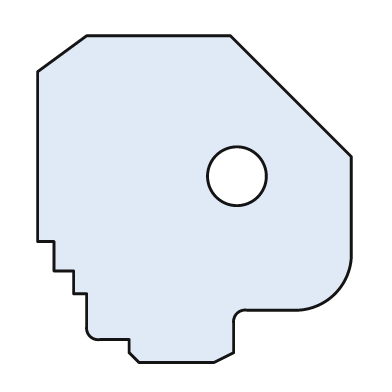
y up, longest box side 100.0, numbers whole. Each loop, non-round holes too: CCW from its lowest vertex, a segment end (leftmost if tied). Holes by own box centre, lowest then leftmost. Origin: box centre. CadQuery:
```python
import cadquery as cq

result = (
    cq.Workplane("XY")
    .moveTo(-17.0, -50.0)
    .lineTo(6.0, -50.0)
    .lineTo(12.0, -47.0)
    .lineTo(12.0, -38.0)
    .threePointArc((13.0, -35.0), (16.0, -34.0))
    .lineTo(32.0, -34.0)
    .threePointArc((43.0, -29.0), (48.0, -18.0))
    .lineTo(48.0, 13.0)
    .lineTo(11.0, 50.0)
    .lineTo(-33.0, 50.0)
    .lineTo(-48.0, 39.0)
    .lineTo(-48.0, -13.0)
    .lineTo(-43.0, -13.0)
    .lineTo(-43.0, -22.0)
    .lineTo(-37.0, -22.0)
    .lineTo(-37.0, -29.0)
    .lineTo(-33.0, -29.0)
    .lineTo(-33.0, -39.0)
    .threePointArc((-32.0, -42.0), (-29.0, -43.0))
    .lineTo(-20.0, -43.0)
    .lineTo(-20.0, -47.0)
    .close()
    .moveTo(13.0, 7.0)
    .circle(9.0)
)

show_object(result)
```